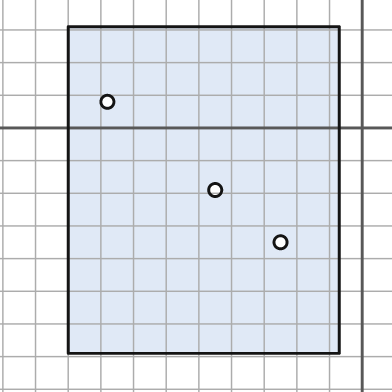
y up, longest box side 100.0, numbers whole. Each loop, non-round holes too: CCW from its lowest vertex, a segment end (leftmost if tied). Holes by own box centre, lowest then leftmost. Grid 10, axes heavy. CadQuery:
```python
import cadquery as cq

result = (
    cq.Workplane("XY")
    .moveTo(-90.0, -69.0)
    .lineTo(-7.0, -69.0)
    .lineTo(-7.0, 31.0)
    .lineTo(-90.0, 31.0)
    .close()
    .moveTo(-25.0, -35.0)
    .circle(2.0)
    .moveTo(-45.0, -19.0)
    .circle(2.0)
    .moveTo(-78.0, 8.0)
    .circle(2.0)
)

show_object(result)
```